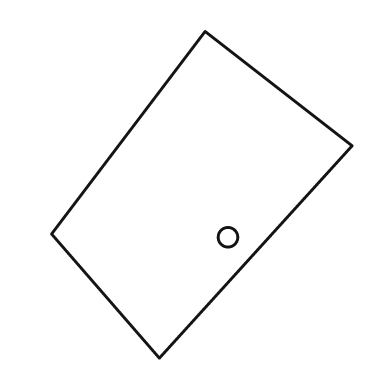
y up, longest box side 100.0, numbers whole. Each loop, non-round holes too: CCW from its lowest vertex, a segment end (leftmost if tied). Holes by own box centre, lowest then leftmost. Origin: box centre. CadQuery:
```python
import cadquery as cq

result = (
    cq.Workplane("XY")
    .moveTo(-13.0, -50.0)
    .lineTo(46.0, 15.0)
    .lineTo(1.0, 50.0)
    .lineTo(-46.0, -12.0)
    .close()
    .moveTo(8.0, -13.0)
    .circle(3.0)
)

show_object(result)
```